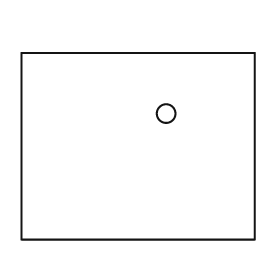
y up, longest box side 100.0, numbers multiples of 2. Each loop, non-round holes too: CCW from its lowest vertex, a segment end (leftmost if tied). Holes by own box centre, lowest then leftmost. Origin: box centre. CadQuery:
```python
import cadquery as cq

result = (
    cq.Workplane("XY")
    .moveTo(-50.0, -40.0)
    .lineTo(50.0, -40.0)
    .lineTo(50.0, 40.0)
    .lineTo(-50.0, 40.0)
    .close()
    .moveTo(12.0, 14.0)
    .circle(4.0)
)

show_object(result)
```